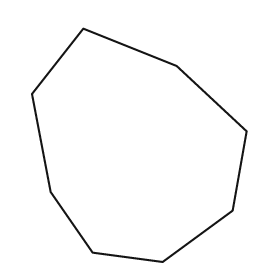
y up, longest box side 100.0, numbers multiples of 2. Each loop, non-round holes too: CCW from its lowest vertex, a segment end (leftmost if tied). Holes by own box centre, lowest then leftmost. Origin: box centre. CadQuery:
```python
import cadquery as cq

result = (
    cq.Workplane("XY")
    .moveTo(10.0, -50.0)
    .lineTo(40.0, -28.0)
    .lineTo(46.0, 6.0)
    .lineTo(16.0, 34.0)
    .lineTo(-24.0, 50.0)
    .lineTo(-46.0, 22.0)
    .lineTo(-38.0, -20.0)
    .lineTo(-20.0, -46.0)
    .close()
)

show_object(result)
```